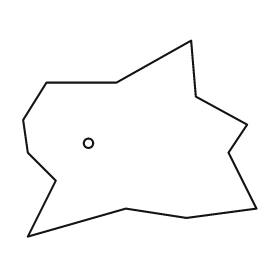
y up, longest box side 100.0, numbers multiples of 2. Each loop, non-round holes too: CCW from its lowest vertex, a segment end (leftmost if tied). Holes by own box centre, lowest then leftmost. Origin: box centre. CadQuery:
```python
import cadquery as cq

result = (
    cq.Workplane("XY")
    .moveTo(-48.0, -42.0)
    .lineTo(-6.0, -30.0)
    .lineTo(20.0, -34.0)
    .lineTo(50.0, -30.0)
    .lineTo(38.0, -6.0)
    .lineTo(46.0, 6.0)
    .lineTo(24.0, 18.0)
    .lineTo(22.0, 42.0)
    .lineTo(-10.0, 24.0)
    .lineTo(-40.0, 24.0)
    .lineTo(-50.0, 8.0)
    .lineTo(-48.0, -6.0)
    .lineTo(-36.0, -18.0)
    .close()
    .moveTo(-22.0, -2.0)
    .circle(2.0)
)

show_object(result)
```